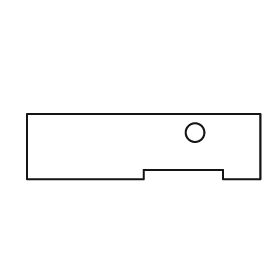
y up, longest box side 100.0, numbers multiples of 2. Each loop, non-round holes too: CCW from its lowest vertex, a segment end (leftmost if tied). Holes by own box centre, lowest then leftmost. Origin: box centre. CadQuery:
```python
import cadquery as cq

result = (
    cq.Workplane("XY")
    .moveTo(-50.0, -14.0)
    .lineTo(0.0, -14.0)
    .lineTo(0.0, -10.0)
    .lineTo(34.0, -10.0)
    .lineTo(34.0, -14.0)
    .lineTo(50.0, -14.0)
    .lineTo(50.0, 14.0)
    .lineTo(-50.0, 14.0)
    .close()
    .moveTo(22.0, 6.0)
    .circle(4.0)
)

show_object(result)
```